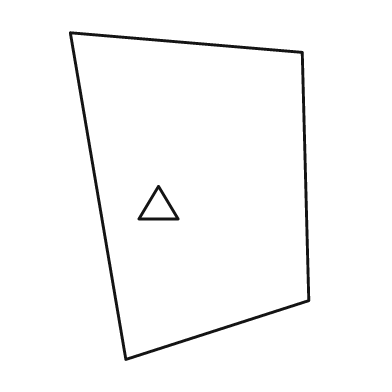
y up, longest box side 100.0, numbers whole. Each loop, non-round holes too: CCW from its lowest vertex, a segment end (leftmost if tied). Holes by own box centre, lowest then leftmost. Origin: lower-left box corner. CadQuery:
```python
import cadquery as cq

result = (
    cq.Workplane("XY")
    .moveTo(17.0, 0.0)
    .lineTo(73.0, 18.0)
    .lineTo(71.0, 94.0)
    .lineTo(0.0, 100.0)
    .close()
    .moveTo(21.0, 43.0)
    .lineTo(33.0, 43.0)
    .lineTo(27.0, 53.0)
    .close()
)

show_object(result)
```